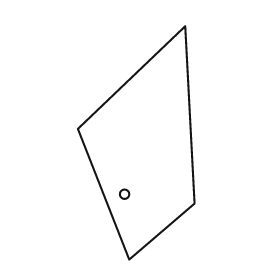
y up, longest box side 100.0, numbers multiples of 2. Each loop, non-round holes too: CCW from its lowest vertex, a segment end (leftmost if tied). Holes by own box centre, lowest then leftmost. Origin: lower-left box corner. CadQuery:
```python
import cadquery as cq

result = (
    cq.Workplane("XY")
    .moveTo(22.0, 0.0)
    .lineTo(50.0, 24.0)
    .lineTo(46.0, 100.0)
    .lineTo(0.0, 56.0)
    .close()
    .moveTo(20.0, 28.0)
    .circle(2.0)
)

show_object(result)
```